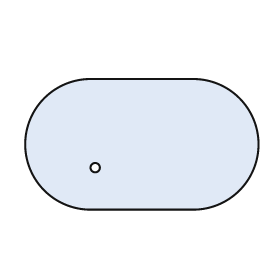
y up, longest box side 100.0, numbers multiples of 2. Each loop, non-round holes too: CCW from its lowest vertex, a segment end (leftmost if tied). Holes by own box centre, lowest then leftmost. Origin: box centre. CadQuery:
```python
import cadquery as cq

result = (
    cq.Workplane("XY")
    .moveTo(-22.0, -28.0)
    .lineTo(22.0, -28.0)
    .threePointArc((50.0, 0.0), (22.0, 28.0))
    .lineTo(-22.0, 28.0)
    .threePointArc((-50.0, 0.0), (-22.0, -28.0))
    .close()
    .moveTo(-20.0, -10.0)
    .circle(2.0)
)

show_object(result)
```